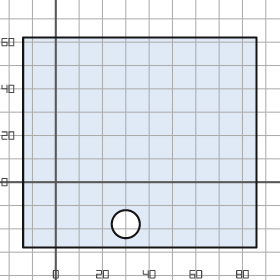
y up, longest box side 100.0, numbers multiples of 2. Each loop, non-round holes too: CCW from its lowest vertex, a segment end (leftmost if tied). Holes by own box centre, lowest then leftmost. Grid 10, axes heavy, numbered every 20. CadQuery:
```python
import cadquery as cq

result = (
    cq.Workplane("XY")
    .moveTo(-14.0, -28.0)
    .lineTo(86.0, -28.0)
    .lineTo(86.0, 62.0)
    .lineTo(-14.0, 62.0)
    .close()
    .moveTo(30.0, -18.0)
    .circle(6.0)
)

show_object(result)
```